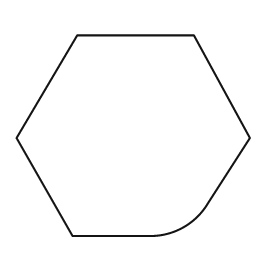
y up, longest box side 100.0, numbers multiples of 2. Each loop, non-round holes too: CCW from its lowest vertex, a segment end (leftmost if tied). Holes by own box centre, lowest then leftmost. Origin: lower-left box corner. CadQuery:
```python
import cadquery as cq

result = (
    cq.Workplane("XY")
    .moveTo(24.0, 0.0)
    .lineTo(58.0, 0.0)
    .threePointArc((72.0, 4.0), (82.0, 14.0))
    .lineTo(100.0, 42.0)
    .lineTo(76.0, 86.0)
    .lineTo(26.0, 86.0)
    .lineTo(0.0, 42.0)
    .close()
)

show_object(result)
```